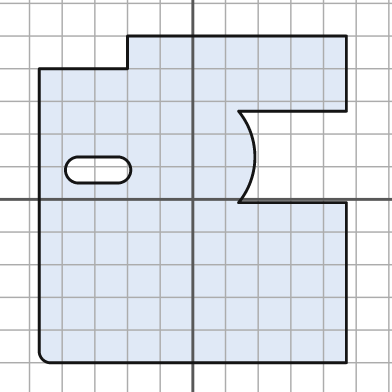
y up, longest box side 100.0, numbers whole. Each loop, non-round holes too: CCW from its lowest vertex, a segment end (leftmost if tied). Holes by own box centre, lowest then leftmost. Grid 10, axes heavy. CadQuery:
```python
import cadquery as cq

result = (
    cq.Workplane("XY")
    .moveTo(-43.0, -50.0)
    .lineTo(47.0, -50.0)
    .lineTo(47.0, -1.0)
    .lineTo(14.0, -1.0)
    .threePointArc((19.0, 13.0), (14.0, 27.0))
    .lineTo(47.0, 27.0)
    .lineTo(47.0, 50.0)
    .lineTo(-20.0, 50.0)
    .lineTo(-20.0, 40.0)
    .lineTo(-47.0, 40.0)
    .lineTo(-47.0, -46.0)
    .threePointArc((-46.0, -49.0), (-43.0, -50.0))
    .close()
    .moveTo(-35.0, 5.0)
    .lineTo(-23.0, 5.0)
    .threePointArc((-19.0, 9.0), (-23.0, 13.0))
    .lineTo(-35.0, 13.0)
    .threePointArc((-39.0, 9.0), (-35.0, 5.0))
    .close()
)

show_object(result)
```